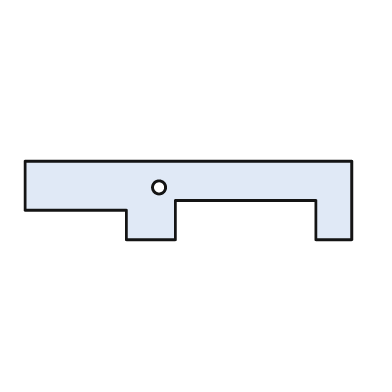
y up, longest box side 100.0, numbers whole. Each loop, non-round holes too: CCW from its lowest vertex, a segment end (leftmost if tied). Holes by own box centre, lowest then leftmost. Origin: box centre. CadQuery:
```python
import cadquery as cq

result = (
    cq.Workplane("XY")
    .moveTo(-19.0, -12.0)
    .lineTo(-4.0, -12.0)
    .lineTo(-4.0, 0.0)
    .lineTo(39.0, 0.0)
    .lineTo(39.0, -12.0)
    .lineTo(50.0, -12.0)
    .lineTo(50.0, 12.0)
    .lineTo(-50.0, 12.0)
    .lineTo(-50.0, -3.0)
    .lineTo(-19.0, -3.0)
    .close()
    .moveTo(-9.0, 4.0)
    .circle(2.0)
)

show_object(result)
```